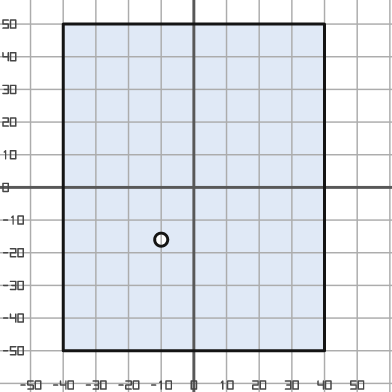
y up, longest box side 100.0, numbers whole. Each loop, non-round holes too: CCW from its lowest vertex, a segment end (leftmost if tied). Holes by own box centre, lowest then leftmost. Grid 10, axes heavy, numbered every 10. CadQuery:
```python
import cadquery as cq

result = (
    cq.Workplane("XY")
    .moveTo(-40.0, -50.0)
    .lineTo(40.0, -50.0)
    .lineTo(40.0, 50.0)
    .lineTo(-40.0, 50.0)
    .close()
    .moveTo(-10.0, -16.0)
    .circle(2.0)
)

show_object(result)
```